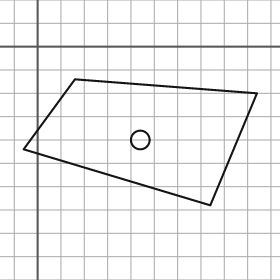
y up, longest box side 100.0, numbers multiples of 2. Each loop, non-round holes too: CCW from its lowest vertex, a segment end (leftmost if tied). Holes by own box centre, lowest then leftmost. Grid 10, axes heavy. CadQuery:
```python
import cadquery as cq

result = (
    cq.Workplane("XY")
    .moveTo(74.0, -68.0)
    .lineTo(94.0, -20.0)
    .lineTo(16.0, -14.0)
    .lineTo(-6.0, -44.0)
    .close()
    .moveTo(44.0, -40.0)
    .circle(4.0)
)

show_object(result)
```